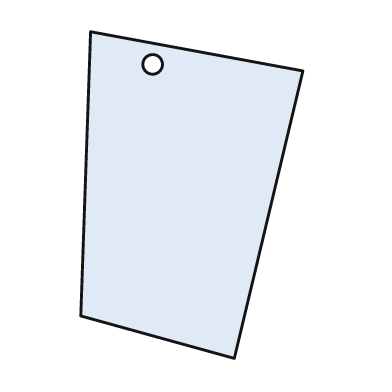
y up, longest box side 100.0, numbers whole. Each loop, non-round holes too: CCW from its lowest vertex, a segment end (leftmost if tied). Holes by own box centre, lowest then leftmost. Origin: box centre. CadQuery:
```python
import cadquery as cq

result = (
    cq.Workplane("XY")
    .moveTo(13.0, -50.0)
    .lineTo(34.0, 38.0)
    .lineTo(-31.0, 50.0)
    .lineTo(-34.0, -37.0)
    .close()
    .moveTo(-12.0, 40.0)
    .circle(3.0)
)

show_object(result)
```